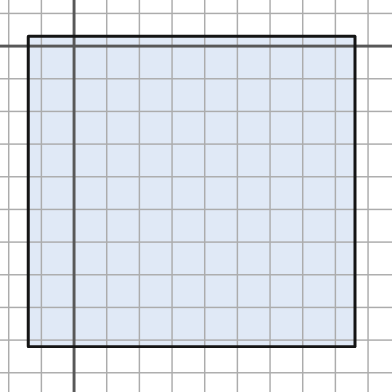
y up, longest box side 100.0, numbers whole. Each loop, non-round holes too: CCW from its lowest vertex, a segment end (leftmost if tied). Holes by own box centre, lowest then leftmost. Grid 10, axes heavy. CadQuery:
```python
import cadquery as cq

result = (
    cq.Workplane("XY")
    .moveTo(-14.0, -92.0)
    .lineTo(86.0, -92.0)
    .lineTo(86.0, 3.0)
    .lineTo(-14.0, 3.0)
    .close()
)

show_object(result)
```